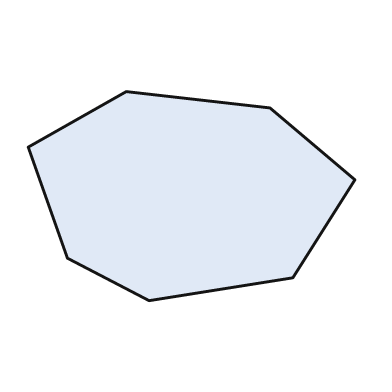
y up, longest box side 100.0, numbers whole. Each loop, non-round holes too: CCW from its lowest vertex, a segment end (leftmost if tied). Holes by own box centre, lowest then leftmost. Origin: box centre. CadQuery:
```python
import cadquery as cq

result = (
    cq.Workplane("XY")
    .moveTo(-13.0, -32.0)
    .lineTo(31.0, -25.0)
    .lineTo(50.0, 5.0)
    .lineTo(24.0, 27.0)
    .lineTo(-20.0, 32.0)
    .lineTo(-50.0, 15.0)
    .lineTo(-38.0, -19.0)
    .close()
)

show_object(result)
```